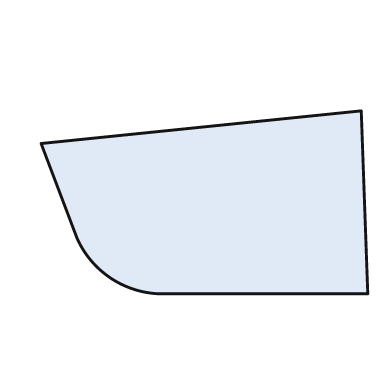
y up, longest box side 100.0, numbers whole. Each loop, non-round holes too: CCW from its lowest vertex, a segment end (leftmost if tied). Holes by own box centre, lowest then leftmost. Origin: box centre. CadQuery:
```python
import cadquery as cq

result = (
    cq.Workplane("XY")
    .moveTo(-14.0, -28.0)
    .lineTo(50.0, -28.0)
    .lineTo(48.0, 28.0)
    .lineTo(-50.0, 18.0)
    .lineTo(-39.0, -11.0)
    .threePointArc((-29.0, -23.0), (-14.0, -28.0))
    .close()
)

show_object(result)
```